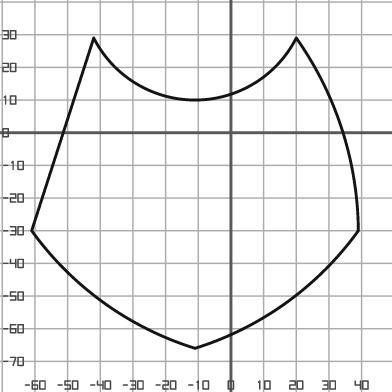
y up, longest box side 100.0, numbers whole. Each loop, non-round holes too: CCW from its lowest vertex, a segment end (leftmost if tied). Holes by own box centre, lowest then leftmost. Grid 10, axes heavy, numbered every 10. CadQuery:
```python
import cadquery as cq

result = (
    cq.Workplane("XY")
    .moveTo(-11.0, -66.0)
    .threePointArc((17.0, -52.0), (39.0, -30.0))
    .threePointArc((34.0, 1.0), (20.0, 29.0))
    .threePointArc((-11.0, 10.0), (-42.0, 29.0))
    .lineTo(-61.0, -30.0)
    .threePointArc((-39.0, -52.0), (-11.0, -66.0))
    .close()
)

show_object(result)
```